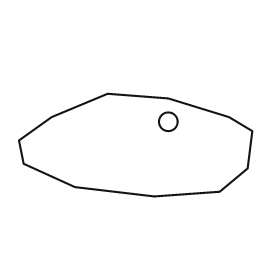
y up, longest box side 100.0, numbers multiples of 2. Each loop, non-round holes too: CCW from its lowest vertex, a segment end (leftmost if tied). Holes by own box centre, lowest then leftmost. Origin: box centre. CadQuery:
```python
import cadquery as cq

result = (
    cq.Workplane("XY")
    .moveTo(8.0, -22.0)
    .lineTo(36.0, -20.0)
    .lineTo(48.0, -10.0)
    .lineTo(50.0, 6.0)
    .lineTo(40.0, 12.0)
    .lineTo(14.0, 20.0)
    .lineTo(-12.0, 22.0)
    .lineTo(-36.0, 12.0)
    .lineTo(-50.0, 2.0)
    .lineTo(-48.0, -8.0)
    .lineTo(-26.0, -18.0)
    .close()
    .moveTo(14.0, 10.0)
    .circle(4.0)
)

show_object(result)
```